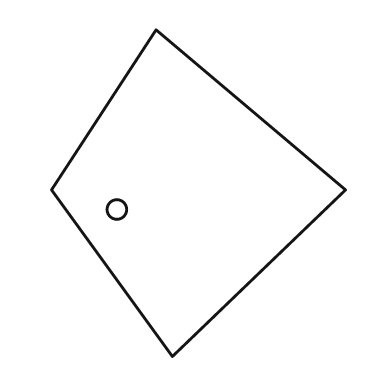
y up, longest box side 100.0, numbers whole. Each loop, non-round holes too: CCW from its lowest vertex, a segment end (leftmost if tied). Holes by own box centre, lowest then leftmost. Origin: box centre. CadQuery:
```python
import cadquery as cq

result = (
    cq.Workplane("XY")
    .moveTo(-8.0, -50.0)
    .lineTo(45.0, 1.0)
    .lineTo(-13.0, 50.0)
    .lineTo(-45.0, 1.0)
    .close()
    .moveTo(-25.0, -5.0)
    .circle(3.0)
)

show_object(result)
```